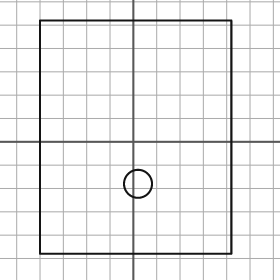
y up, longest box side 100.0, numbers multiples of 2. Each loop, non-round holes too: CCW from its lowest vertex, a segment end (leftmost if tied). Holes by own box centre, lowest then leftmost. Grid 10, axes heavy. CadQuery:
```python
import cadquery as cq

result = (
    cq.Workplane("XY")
    .moveTo(-40.0, -48.0)
    .lineTo(42.0, -48.0)
    .lineTo(42.0, 52.0)
    .lineTo(-40.0, 52.0)
    .close()
    .moveTo(2.0, -18.0)
    .circle(6.0)
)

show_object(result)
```